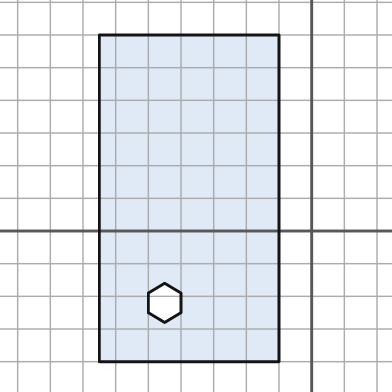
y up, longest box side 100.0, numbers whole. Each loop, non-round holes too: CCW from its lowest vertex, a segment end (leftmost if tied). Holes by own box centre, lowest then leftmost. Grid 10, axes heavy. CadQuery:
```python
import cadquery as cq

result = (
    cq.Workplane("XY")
    .moveTo(-65.0, -40.0)
    .lineTo(-10.0, -40.0)
    .lineTo(-10.0, 60.0)
    .lineTo(-65.0, 60.0)
    .close()
    .moveTo(-45.0, -28.0)
    .lineTo(-40.0, -25.0)
    .lineTo(-40.0, -19.0)
    .lineTo(-45.0, -16.0)
    .lineTo(-50.0, -19.0)
    .lineTo(-50.0, -25.0)
    .close()
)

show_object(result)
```